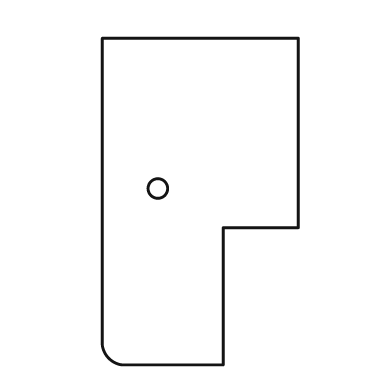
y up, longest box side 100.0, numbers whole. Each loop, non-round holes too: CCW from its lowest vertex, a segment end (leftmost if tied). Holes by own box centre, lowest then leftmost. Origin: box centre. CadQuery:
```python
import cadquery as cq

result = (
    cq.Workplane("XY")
    .moveTo(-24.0, -50.0)
    .lineTo(7.0, -50.0)
    .lineTo(7.0, -8.0)
    .lineTo(30.0, -8.0)
    .lineTo(30.0, 50.0)
    .lineTo(-30.0, 50.0)
    .lineTo(-30.0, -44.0)
    .threePointArc((-28.0, -48.0), (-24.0, -50.0))
    .close()
    .moveTo(-13.0, 4.0)
    .circle(3.0)
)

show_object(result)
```